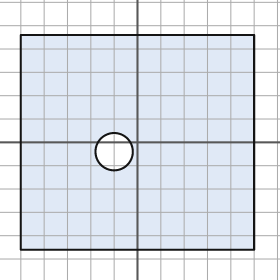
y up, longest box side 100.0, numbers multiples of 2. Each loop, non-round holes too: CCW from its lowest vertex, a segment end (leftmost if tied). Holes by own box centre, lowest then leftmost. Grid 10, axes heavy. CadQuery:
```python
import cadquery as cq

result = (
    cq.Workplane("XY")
    .moveTo(-50.0, -46.0)
    .lineTo(50.0, -46.0)
    .lineTo(50.0, 46.0)
    .lineTo(-50.0, 46.0)
    .close()
    .moveTo(-10.0, -4.0)
    .circle(8.0)
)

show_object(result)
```